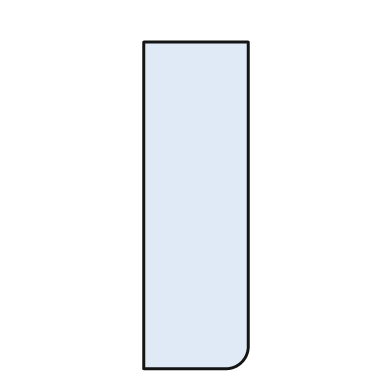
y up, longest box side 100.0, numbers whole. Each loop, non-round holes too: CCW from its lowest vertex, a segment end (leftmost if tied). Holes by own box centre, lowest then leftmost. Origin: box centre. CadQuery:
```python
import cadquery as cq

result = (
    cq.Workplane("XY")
    .moveTo(-16.0, -50.0)
    .lineTo(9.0, -50.0)
    .threePointArc((14.0, -48.0), (16.0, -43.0))
    .lineTo(16.0, 50.0)
    .lineTo(-16.0, 50.0)
    .close()
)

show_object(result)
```